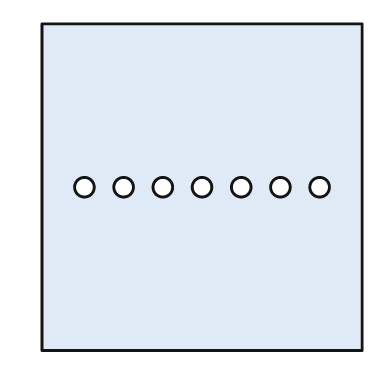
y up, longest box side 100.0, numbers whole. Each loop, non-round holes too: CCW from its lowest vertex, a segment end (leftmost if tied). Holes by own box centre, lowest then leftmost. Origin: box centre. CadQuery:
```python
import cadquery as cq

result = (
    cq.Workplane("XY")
    .moveTo(-49.0, -50.0)
    .lineTo(49.0, -50.0)
    .lineTo(49.0, 50.0)
    .lineTo(-49.0, 50.0)
    .close()
    .moveTo(-36.0, 0.0)
    .circle(3.0)
    .moveTo(-24.0, 0.0)
    .circle(3.0)
    .moveTo(-12.0, 0.0)
    .circle(3.0)
    .moveTo(0.0, 0.0)
    .circle(3.0)
    .moveTo(12.0, 0.0)
    .circle(3.0)
    .moveTo(24.0, 0.0)
    .circle(3.0)
    .moveTo(36.0, 0.0)
    .circle(3.0)
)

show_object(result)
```